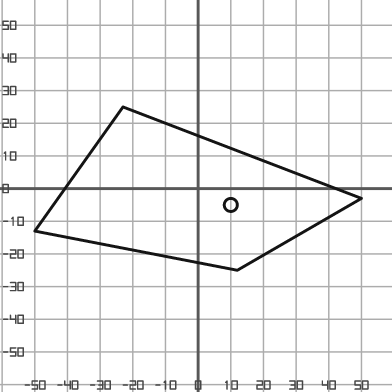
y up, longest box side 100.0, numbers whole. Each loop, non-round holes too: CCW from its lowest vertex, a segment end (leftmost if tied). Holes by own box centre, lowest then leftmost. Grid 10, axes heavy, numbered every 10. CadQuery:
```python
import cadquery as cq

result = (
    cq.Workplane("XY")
    .moveTo(12.0, -25.0)
    .lineTo(50.0, -3.0)
    .lineTo(-23.0, 25.0)
    .lineTo(-50.0, -13.0)
    .close()
    .moveTo(10.0, -5.0)
    .circle(2.0)
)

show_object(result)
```